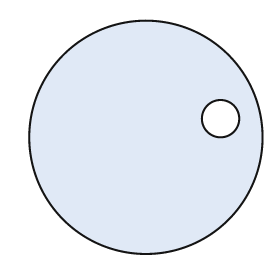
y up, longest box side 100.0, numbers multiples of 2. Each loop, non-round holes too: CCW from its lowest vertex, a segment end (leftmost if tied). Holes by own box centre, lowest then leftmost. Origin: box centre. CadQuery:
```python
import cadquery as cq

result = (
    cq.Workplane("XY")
    .moveTo(0.0, 0.0)
    .circle(50.0)
    .moveTo(32.0, 8.0)
    .circle(8.0)
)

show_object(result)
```